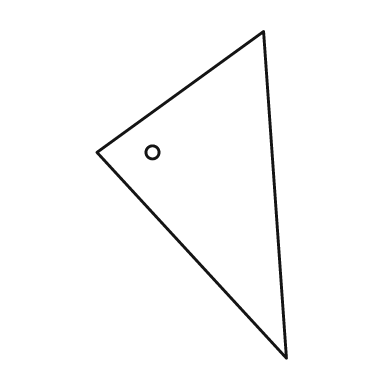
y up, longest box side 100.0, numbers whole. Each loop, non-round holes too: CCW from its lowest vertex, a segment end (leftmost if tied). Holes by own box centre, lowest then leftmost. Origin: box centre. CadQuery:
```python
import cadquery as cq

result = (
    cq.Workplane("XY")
    .moveTo(29.0, -50.0)
    .lineTo(22.0, 50.0)
    .lineTo(-29.0, 13.0)
    .close()
    .moveTo(-12.0, 13.0)
    .circle(2.0)
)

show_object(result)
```